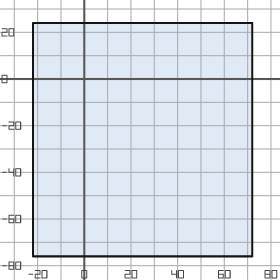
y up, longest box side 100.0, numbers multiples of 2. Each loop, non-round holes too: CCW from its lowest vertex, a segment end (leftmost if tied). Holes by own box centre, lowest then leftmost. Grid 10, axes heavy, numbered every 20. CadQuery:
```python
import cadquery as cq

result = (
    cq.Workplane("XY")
    .moveTo(-22.0, -76.0)
    .lineTo(72.0, -76.0)
    .lineTo(72.0, 24.0)
    .lineTo(-22.0, 24.0)
    .close()
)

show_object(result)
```